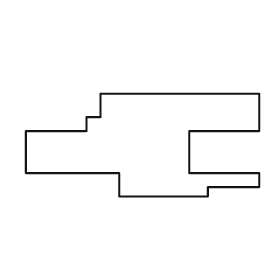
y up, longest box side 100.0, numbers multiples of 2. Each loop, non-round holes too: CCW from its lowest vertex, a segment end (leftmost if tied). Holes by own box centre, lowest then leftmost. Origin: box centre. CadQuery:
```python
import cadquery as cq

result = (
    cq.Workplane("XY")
    .moveTo(-10.0, -22.0)
    .lineTo(28.0, -22.0)
    .lineTo(28.0, -18.0)
    .lineTo(50.0, -18.0)
    .lineTo(50.0, -12.0)
    .lineTo(20.0, -12.0)
    .lineTo(20.0, 6.0)
    .lineTo(50.0, 6.0)
    .lineTo(50.0, 22.0)
    .lineTo(-18.0, 22.0)
    .lineTo(-18.0, 12.0)
    .lineTo(-24.0, 12.0)
    .lineTo(-24.0, 6.0)
    .lineTo(-50.0, 6.0)
    .lineTo(-50.0, -12.0)
    .lineTo(-10.0, -12.0)
    .close()
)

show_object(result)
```